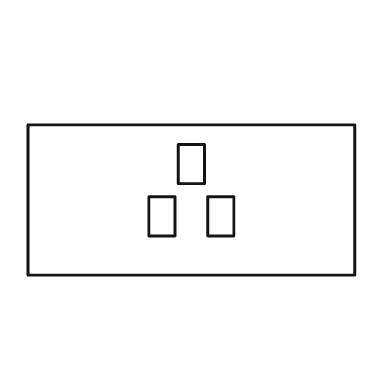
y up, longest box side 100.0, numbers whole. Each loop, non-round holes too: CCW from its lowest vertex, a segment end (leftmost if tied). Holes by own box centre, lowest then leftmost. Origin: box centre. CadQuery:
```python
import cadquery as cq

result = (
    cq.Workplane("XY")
    .moveTo(-50.0, -23.0)
    .lineTo(50.0, -23.0)
    .lineTo(50.0, 23.0)
    .lineTo(-50.0, 23.0)
    .close()
    .moveTo(-13.0, -11.0)
    .lineTo(-5.0, -11.0)
    .lineTo(-5.0, 1.0)
    .lineTo(-13.0, 1.0)
    .close()
    .moveTo(5.0, -11.0)
    .lineTo(13.0, -11.0)
    .lineTo(13.0, 1.0)
    .lineTo(5.0, 1.0)
    .close()
    .moveTo(-4.0, 5.0)
    .lineTo(4.0, 5.0)
    .lineTo(4.0, 17.0)
    .lineTo(-4.0, 17.0)
    .close()
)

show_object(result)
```